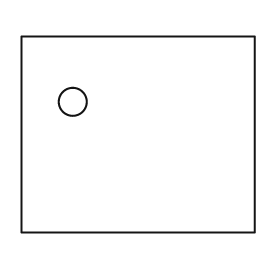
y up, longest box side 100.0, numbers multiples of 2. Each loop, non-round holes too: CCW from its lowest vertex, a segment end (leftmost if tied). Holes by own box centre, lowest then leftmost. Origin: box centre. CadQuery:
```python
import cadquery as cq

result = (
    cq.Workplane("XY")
    .moveTo(-50.0, -42.0)
    .lineTo(50.0, -42.0)
    .lineTo(50.0, 42.0)
    .lineTo(-50.0, 42.0)
    .close()
    .moveTo(-28.0, 14.0)
    .circle(6.0)
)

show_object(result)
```